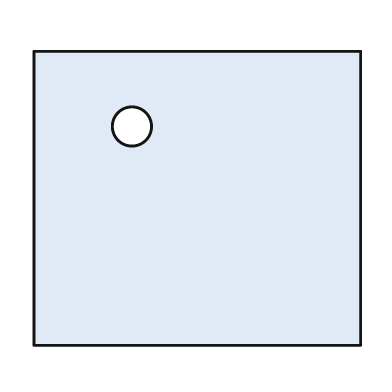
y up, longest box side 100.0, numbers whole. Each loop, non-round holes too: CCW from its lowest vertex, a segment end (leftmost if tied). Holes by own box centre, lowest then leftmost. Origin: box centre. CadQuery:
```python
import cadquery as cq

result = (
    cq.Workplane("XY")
    .moveTo(-50.0, -45.0)
    .lineTo(50.0, -45.0)
    .lineTo(50.0, 45.0)
    .lineTo(-50.0, 45.0)
    .close()
    .moveTo(-20.0, 22.0)
    .circle(6.0)
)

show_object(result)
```